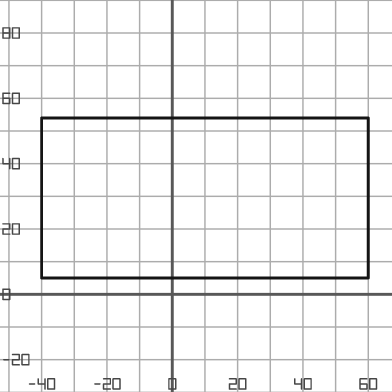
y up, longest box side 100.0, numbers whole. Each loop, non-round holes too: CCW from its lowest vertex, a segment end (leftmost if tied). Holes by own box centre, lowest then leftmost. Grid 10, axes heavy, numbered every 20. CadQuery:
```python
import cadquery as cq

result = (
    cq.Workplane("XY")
    .moveTo(-40.0, 5.0)
    .lineTo(60.0, 5.0)
    .lineTo(60.0, 54.0)
    .lineTo(-40.0, 54.0)
    .close()
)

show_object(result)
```